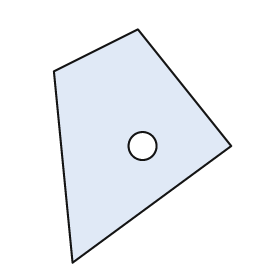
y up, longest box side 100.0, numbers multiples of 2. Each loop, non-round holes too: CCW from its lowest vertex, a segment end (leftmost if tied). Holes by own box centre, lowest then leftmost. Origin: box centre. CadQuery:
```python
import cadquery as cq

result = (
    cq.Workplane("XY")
    .moveTo(-30.0, -50.0)
    .lineTo(38.0, 0.0)
    .lineTo(-2.0, 50.0)
    .lineTo(-38.0, 32.0)
    .close()
    .moveTo(0.0, 0.0)
    .circle(6.0)
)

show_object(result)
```